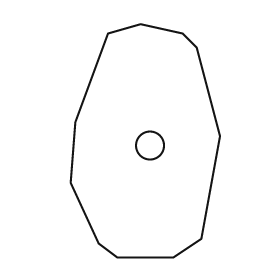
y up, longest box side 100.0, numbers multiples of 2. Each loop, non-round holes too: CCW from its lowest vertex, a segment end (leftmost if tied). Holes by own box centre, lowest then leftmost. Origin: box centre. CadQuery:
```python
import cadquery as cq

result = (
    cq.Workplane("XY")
    .moveTo(-12.0, -50.0)
    .lineTo(12.0, -50.0)
    .lineTo(24.0, -42.0)
    .lineTo(32.0, 2.0)
    .lineTo(22.0, 40.0)
    .lineTo(16.0, 46.0)
    .lineTo(-2.0, 50.0)
    .lineTo(-16.0, 46.0)
    .lineTo(-30.0, 8.0)
    .lineTo(-32.0, -18.0)
    .lineTo(-20.0, -44.0)
    .close()
    .moveTo(2.0, -2.0)
    .circle(6.0)
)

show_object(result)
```